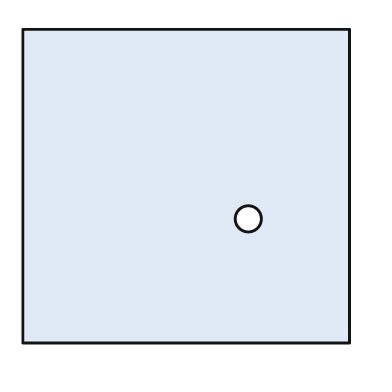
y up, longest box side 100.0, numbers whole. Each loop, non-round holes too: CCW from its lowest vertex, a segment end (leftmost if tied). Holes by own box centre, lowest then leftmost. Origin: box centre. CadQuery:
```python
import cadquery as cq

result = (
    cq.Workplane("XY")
    .moveTo(-50.0, -48.0)
    .lineTo(50.0, -48.0)
    .lineTo(50.0, 48.0)
    .lineTo(-50.0, 48.0)
    .close()
    .moveTo(19.0, -10.0)
    .circle(4.0)
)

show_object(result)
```